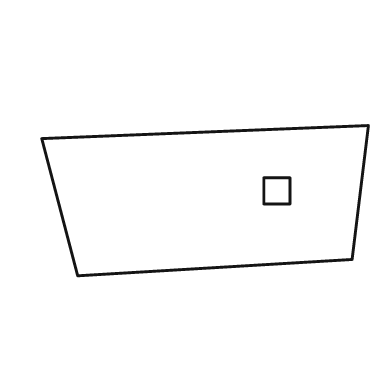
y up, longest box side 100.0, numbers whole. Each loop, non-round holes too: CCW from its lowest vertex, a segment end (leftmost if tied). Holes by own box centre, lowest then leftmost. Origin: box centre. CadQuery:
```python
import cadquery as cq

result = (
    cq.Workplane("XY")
    .moveTo(-39.0, -23.0)
    .lineTo(45.0, -18.0)
    .lineTo(50.0, 23.0)
    .lineTo(-50.0, 19.0)
    .close()
    .moveTo(18.0, -1.0)
    .lineTo(26.0, -1.0)
    .lineTo(26.0, 7.0)
    .lineTo(18.0, 7.0)
    .close()
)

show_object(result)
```